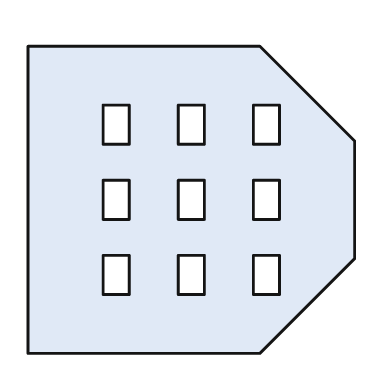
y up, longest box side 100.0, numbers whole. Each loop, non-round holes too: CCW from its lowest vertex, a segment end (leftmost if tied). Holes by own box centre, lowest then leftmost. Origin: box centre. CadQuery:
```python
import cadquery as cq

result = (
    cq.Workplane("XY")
    .moveTo(-50.0, -47.0)
    .lineTo(21.0, -47.0)
    .lineTo(50.0, -18.0)
    .lineTo(50.0, 18.0)
    .lineTo(21.0, 47.0)
    .lineTo(-50.0, 47.0)
    .close()
    .moveTo(-27.0, -29.0)
    .lineTo(-19.0, -29.0)
    .lineTo(-19.0, -17.0)
    .lineTo(-27.0, -17.0)
    .close()
    .moveTo(-4.0, -29.0)
    .lineTo(4.0, -29.0)
    .lineTo(4.0, -17.0)
    .lineTo(-4.0, -17.0)
    .close()
    .moveTo(19.0, -29.0)
    .lineTo(27.0, -29.0)
    .lineTo(27.0, -17.0)
    .lineTo(19.0, -17.0)
    .close()
    .moveTo(-27.0, -6.0)
    .lineTo(-19.0, -6.0)
    .lineTo(-19.0, 6.0)
    .lineTo(-27.0, 6.0)
    .close()
    .moveTo(-4.0, -6.0)
    .lineTo(4.0, -6.0)
    .lineTo(4.0, 6.0)
    .lineTo(-4.0, 6.0)
    .close()
    .moveTo(19.0, -6.0)
    .lineTo(27.0, -6.0)
    .lineTo(27.0, 6.0)
    .lineTo(19.0, 6.0)
    .close()
    .moveTo(-27.0, 17.0)
    .lineTo(-19.0, 17.0)
    .lineTo(-19.0, 29.0)
    .lineTo(-27.0, 29.0)
    .close()
    .moveTo(-4.0, 17.0)
    .lineTo(4.0, 17.0)
    .lineTo(4.0, 29.0)
    .lineTo(-4.0, 29.0)
    .close()
    .moveTo(19.0, 17.0)
    .lineTo(27.0, 17.0)
    .lineTo(27.0, 29.0)
    .lineTo(19.0, 29.0)
    .close()
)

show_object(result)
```